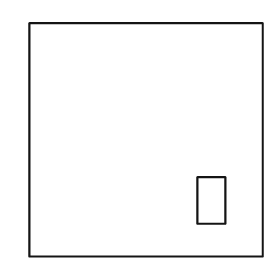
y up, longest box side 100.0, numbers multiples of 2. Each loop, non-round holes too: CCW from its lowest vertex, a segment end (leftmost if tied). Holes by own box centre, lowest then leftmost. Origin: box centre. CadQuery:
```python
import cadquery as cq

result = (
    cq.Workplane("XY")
    .moveTo(-50.0, -50.0)
    .lineTo(50.0, -50.0)
    .lineTo(50.0, 50.0)
    .lineTo(-50.0, 50.0)
    .close()
    .moveTo(22.0, -36.0)
    .lineTo(34.0, -36.0)
    .lineTo(34.0, -16.0)
    .lineTo(22.0, -16.0)
    .close()
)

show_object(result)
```